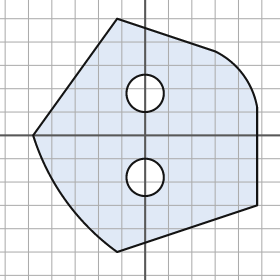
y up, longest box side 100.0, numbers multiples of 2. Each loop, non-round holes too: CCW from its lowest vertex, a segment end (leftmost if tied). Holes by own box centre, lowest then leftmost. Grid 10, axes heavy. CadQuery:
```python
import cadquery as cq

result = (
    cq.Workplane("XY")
    .moveTo(-12.0, -50.0)
    .lineTo(48.0, -30.0)
    .lineTo(48.0, 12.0)
    .threePointArc((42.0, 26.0), (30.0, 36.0))
    .lineTo(-12.0, 50.0)
    .lineTo(-48.0, 0.0)
    .threePointArc((-34.0, -28.0), (-12.0, -50.0))
    .close()
    .moveTo(0.0, -18.0)
    .circle(8.0)
    .moveTo(0.0, 18.0)
    .circle(8.0)
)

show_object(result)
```